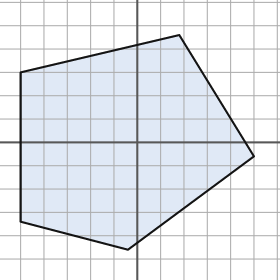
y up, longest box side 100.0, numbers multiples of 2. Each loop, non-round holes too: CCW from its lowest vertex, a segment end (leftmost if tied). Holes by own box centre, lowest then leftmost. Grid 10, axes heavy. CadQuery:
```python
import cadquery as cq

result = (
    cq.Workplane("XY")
    .moveTo(-4.0, -46.0)
    .lineTo(50.0, -6.0)
    .lineTo(18.0, 46.0)
    .lineTo(-50.0, 30.0)
    .lineTo(-50.0, -34.0)
    .close()
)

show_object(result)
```